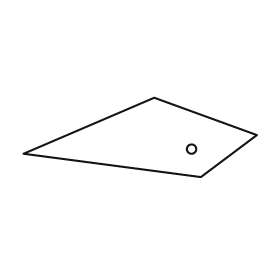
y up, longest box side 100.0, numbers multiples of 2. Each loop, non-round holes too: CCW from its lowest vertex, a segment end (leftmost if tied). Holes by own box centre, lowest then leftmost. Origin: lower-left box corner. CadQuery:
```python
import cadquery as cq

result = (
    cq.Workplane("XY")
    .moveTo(76.0, 0.0)
    .lineTo(100.0, 18.0)
    .lineTo(56.0, 34.0)
    .lineTo(0.0, 10.0)
    .close()
    .moveTo(72.0, 12.0)
    .circle(2.0)
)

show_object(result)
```